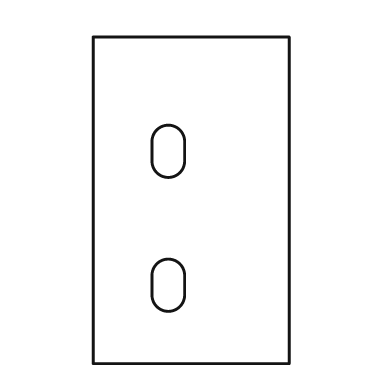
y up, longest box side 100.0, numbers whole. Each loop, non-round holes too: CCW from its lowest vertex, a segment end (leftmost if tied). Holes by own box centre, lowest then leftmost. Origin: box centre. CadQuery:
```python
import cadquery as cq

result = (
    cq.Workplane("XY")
    .moveTo(-30.0, -50.0)
    .lineTo(30.0, -50.0)
    .lineTo(30.0, 50.0)
    .lineTo(-30.0, 50.0)
    .close()
    .moveTo(-12.0, -29.0)
    .threePointArc((-7.0, -34.0), (-2.0, -29.0))
    .lineTo(-2.0, -23.0)
    .threePointArc((-7.0, -18.0), (-12.0, -23.0))
    .close()
    .moveTo(-12.0, 12.0)
    .threePointArc((-7.0, 7.0), (-2.0, 12.0))
    .lineTo(-2.0, 18.0)
    .threePointArc((-7.0, 23.0), (-12.0, 18.0))
    .close()
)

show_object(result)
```